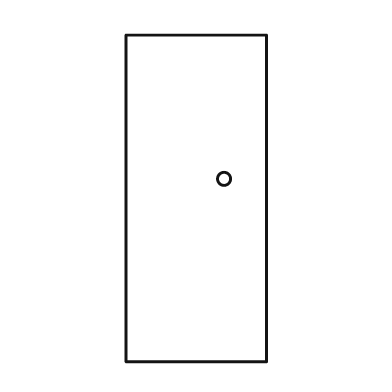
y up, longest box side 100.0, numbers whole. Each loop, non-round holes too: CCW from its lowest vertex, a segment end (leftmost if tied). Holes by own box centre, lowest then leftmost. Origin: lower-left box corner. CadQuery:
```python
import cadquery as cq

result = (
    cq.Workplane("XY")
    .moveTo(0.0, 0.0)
    .lineTo(43.0, 0.0)
    .lineTo(43.0, 100.0)
    .lineTo(0.0, 100.0)
    .close()
    .moveTo(30.0, 56.0)
    .circle(2.0)
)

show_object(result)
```